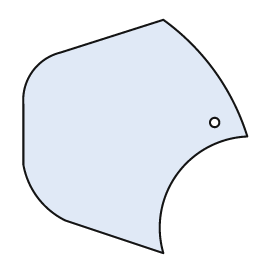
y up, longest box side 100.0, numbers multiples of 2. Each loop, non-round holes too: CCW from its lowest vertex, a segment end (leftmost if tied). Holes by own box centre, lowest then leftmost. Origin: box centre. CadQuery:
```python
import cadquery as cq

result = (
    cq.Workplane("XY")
    .moveTo(12.0, -50.0)
    .threePointArc((18.0, -16.0), (48.0, 0.0))
    .threePointArc((34.0, 28.0), (12.0, 50.0))
    .lineTo(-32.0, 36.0)
    .threePointArc((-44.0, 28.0), (-48.0, 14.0))
    .lineTo(-48.0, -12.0)
    .threePointArc((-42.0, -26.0), (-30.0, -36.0))
    .close()
    .moveTo(34.0, 6.0)
    .circle(2.0)
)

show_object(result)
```